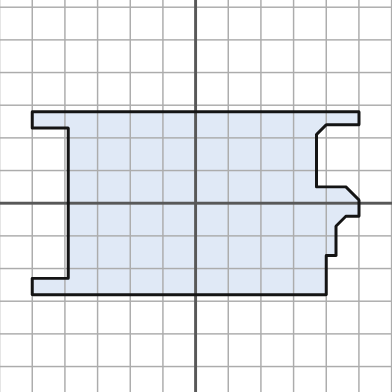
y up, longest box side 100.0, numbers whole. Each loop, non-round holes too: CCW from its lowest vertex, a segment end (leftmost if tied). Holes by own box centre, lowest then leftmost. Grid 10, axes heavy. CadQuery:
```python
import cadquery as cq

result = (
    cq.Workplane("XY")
    .moveTo(-50.0, -28.0)
    .lineTo(40.0, -28.0)
    .lineTo(40.0, -16.0)
    .lineTo(43.0, -16.0)
    .lineTo(43.0, -7.0)
    .lineTo(46.0, -4.0)
    .lineTo(50.0, -4.0)
    .lineTo(50.0, 1.0)
    .lineTo(46.0, 5.0)
    .lineTo(37.0, 5.0)
    .lineTo(37.0, 21.0)
    .lineTo(40.0, 24.0)
    .lineTo(50.0, 24.0)
    .lineTo(50.0, 28.0)
    .lineTo(-50.0, 28.0)
    .lineTo(-50.0, 23.0)
    .lineTo(-39.0, 23.0)
    .lineTo(-39.0, -23.0)
    .lineTo(-50.0, -23.0)
    .close()
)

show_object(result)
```